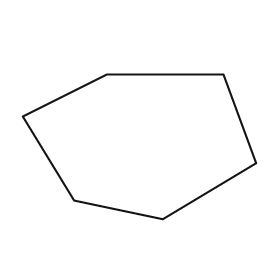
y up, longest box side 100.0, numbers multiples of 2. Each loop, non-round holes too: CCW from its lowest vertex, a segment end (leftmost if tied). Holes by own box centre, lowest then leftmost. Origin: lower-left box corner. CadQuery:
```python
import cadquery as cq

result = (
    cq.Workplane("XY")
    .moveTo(60.0, 0.0)
    .lineTo(100.0, 24.0)
    .lineTo(86.0, 62.0)
    .lineTo(36.0, 62.0)
    .lineTo(0.0, 44.0)
    .lineTo(22.0, 8.0)
    .close()
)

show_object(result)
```